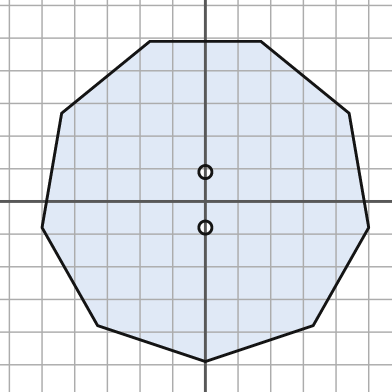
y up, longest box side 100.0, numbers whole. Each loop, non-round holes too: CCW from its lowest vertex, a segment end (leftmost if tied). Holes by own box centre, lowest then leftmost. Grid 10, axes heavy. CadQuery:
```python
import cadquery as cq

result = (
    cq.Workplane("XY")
    .moveTo(0.0, -49.0)
    .lineTo(33.0, -38.0)
    .lineTo(50.0, -8.0)
    .lineTo(44.0, 27.0)
    .lineTo(17.0, 49.0)
    .lineTo(-17.0, 49.0)
    .lineTo(-44.0, 27.0)
    .lineTo(-50.0, -8.0)
    .lineTo(-33.0, -38.0)
    .close()
    .moveTo(0.0, -8.0)
    .circle(2.0)
    .moveTo(0.0, 9.0)
    .circle(2.0)
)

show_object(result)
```